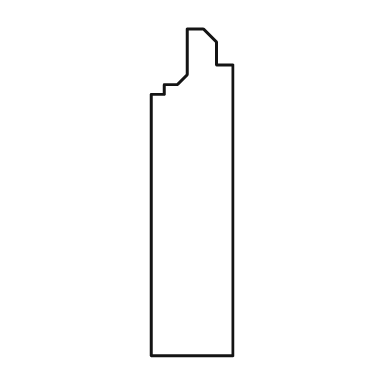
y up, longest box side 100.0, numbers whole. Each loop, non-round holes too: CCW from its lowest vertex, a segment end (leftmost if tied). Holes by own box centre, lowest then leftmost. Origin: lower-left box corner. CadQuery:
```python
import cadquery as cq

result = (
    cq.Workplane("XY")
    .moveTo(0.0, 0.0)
    .lineTo(25.0, 0.0)
    .lineTo(25.0, 89.0)
    .lineTo(20.0, 89.0)
    .lineTo(20.0, 96.0)
    .lineTo(16.0, 100.0)
    .lineTo(11.0, 100.0)
    .lineTo(11.0, 86.0)
    .lineTo(8.0, 83.0)
    .lineTo(4.0, 83.0)
    .lineTo(4.0, 80.0)
    .lineTo(0.0, 80.0)
    .close()
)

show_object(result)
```